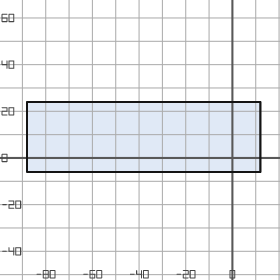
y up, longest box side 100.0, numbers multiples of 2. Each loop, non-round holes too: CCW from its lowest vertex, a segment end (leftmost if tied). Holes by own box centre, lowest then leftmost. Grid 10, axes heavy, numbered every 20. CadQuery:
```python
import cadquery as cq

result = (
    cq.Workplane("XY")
    .moveTo(-88.0, -6.0)
    .lineTo(12.0, -6.0)
    .lineTo(12.0, 24.0)
    .lineTo(-88.0, 24.0)
    .close()
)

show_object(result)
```